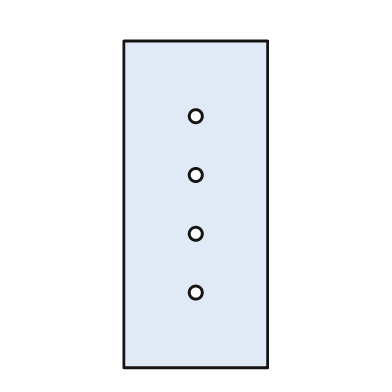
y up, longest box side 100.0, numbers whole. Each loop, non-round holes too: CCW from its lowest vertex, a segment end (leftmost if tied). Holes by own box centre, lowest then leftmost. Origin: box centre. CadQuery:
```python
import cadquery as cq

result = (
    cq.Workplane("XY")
    .moveTo(-22.0, -50.0)
    .lineTo(22.0, -50.0)
    .lineTo(22.0, 50.0)
    .lineTo(-22.0, 50.0)
    .close()
    .moveTo(0.0, -27.0)
    .circle(2.0)
    .moveTo(0.0, -9.0)
    .circle(2.0)
    .moveTo(0.0, 9.0)
    .circle(2.0)
    .moveTo(0.0, 27.0)
    .circle(2.0)
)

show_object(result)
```